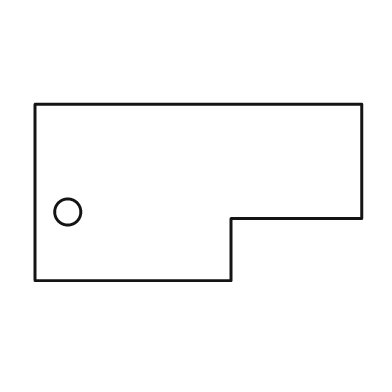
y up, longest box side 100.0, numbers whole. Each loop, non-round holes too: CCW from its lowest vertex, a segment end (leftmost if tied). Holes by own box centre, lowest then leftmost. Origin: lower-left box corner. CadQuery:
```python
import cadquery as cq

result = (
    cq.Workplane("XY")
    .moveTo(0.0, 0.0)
    .lineTo(60.0, 0.0)
    .lineTo(60.0, 19.0)
    .lineTo(100.0, 19.0)
    .lineTo(100.0, 54.0)
    .lineTo(0.0, 54.0)
    .close()
    .moveTo(10.0, 21.0)
    .circle(4.0)
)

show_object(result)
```